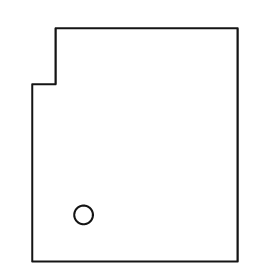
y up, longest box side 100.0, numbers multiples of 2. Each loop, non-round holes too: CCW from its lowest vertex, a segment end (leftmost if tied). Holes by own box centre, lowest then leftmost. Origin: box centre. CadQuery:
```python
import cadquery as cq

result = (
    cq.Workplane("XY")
    .moveTo(-44.0, -50.0)
    .lineTo(44.0, -50.0)
    .lineTo(44.0, 50.0)
    .lineTo(-34.0, 50.0)
    .lineTo(-34.0, 26.0)
    .lineTo(-44.0, 26.0)
    .close()
    .moveTo(-22.0, -30.0)
    .circle(4.0)
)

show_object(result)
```